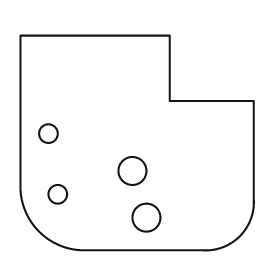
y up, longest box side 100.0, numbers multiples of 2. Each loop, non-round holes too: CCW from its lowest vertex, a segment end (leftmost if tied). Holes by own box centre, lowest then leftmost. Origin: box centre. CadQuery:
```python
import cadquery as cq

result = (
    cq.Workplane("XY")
    .moveTo(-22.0, -46.0)
    .lineTo(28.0, -46.0)
    .threePointArc((44.0, -40.0), (50.0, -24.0))
    .lineTo(50.0, 18.0)
    .lineTo(14.0, 18.0)
    .lineTo(14.0, 46.0)
    .lineTo(-50.0, 46.0)
    .lineTo(-50.0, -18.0)
    .threePointArc((-42.0, -38.0), (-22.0, -46.0))
    .close()
    .moveTo(4.0, -32.0)
    .circle(6.0)
    .moveTo(-34.0, -22.0)
    .circle(4.0)
    .moveTo(-2.0, -12.0)
    .circle(6.0)
    .moveTo(-38.0, 4.0)
    .circle(4.0)
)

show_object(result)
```